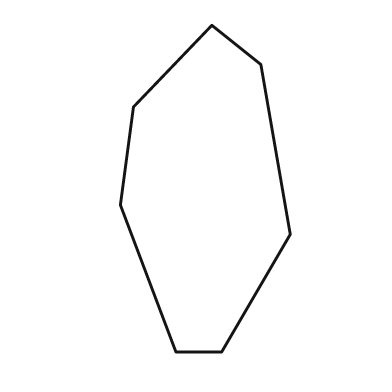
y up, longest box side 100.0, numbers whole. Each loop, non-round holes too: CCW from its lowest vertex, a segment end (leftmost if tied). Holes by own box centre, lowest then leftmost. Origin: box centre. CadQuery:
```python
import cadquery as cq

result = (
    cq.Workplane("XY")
    .moveTo(-9.0, -50.0)
    .lineTo(5.0, -50.0)
    .lineTo(26.0, -14.0)
    .lineTo(17.0, 38.0)
    .lineTo(2.0, 50.0)
    .lineTo(-22.0, 25.0)
    .lineTo(-26.0, -5.0)
    .close()
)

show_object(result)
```